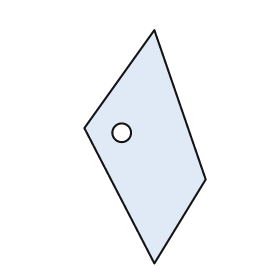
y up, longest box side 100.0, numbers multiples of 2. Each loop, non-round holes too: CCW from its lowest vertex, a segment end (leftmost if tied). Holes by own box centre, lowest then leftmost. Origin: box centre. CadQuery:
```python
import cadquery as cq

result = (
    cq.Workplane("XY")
    .moveTo(4.0, -50.0)
    .lineTo(26.0, -14.0)
    .lineTo(4.0, 50.0)
    .lineTo(-26.0, 8.0)
    .close()
    .moveTo(-10.0, 6.0)
    .circle(4.0)
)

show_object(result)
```